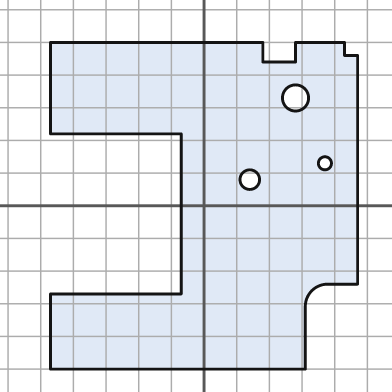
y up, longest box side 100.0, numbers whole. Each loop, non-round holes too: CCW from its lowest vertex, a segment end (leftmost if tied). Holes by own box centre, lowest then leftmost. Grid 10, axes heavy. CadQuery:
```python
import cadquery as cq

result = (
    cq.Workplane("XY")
    .moveTo(-47.0, -50.0)
    .lineTo(31.0, -50.0)
    .lineTo(31.0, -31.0)
    .threePointArc((33.0, -26.0), (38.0, -24.0))
    .lineTo(47.0, -24.0)
    .lineTo(47.0, 46.0)
    .lineTo(43.0, 46.0)
    .lineTo(43.0, 50.0)
    .lineTo(28.0, 50.0)
    .lineTo(28.0, 44.0)
    .lineTo(18.0, 44.0)
    .lineTo(18.0, 50.0)
    .lineTo(-47.0, 50.0)
    .lineTo(-47.0, 22.0)
    .lineTo(-7.0, 22.0)
    .lineTo(-7.0, -27.0)
    .lineTo(-47.0, -27.0)
    .close()
    .moveTo(14.0, 8.0)
    .circle(3.0)
    .moveTo(37.0, 13.0)
    .circle(2.0)
    .moveTo(28.0, 33.0)
    .circle(4.0)
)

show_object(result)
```